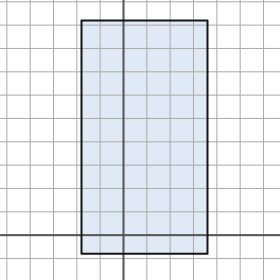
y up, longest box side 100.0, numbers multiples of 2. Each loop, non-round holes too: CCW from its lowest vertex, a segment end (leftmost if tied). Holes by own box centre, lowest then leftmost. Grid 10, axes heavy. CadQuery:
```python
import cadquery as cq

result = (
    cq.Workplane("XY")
    .moveTo(-18.0, -8.0)
    .lineTo(36.0, -8.0)
    .lineTo(36.0, 92.0)
    .lineTo(-18.0, 92.0)
    .close()
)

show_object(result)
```